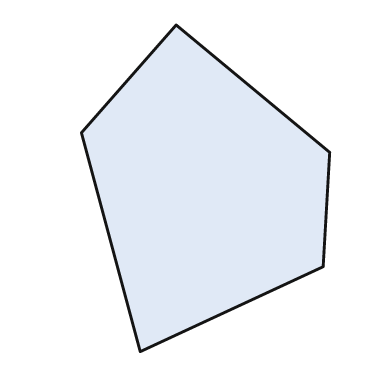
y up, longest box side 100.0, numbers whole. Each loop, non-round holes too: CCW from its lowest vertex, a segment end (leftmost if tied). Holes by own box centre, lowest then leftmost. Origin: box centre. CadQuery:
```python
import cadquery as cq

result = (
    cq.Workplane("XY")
    .moveTo(-20.0, -50.0)
    .lineTo(36.0, -24.0)
    .lineTo(38.0, 11.0)
    .lineTo(-9.0, 50.0)
    .lineTo(-38.0, 17.0)
    .close()
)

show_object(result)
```